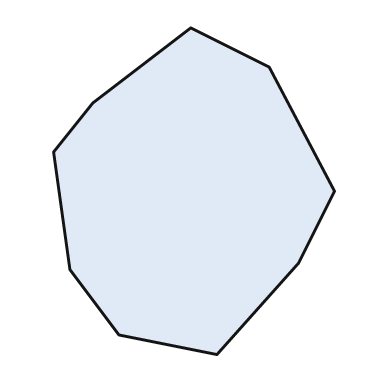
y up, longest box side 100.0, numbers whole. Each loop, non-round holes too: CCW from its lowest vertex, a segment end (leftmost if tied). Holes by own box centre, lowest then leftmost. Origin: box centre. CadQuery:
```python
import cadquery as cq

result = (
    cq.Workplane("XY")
    .moveTo(7.0, -50.0)
    .lineTo(32.0, -22.0)
    .lineTo(43.0, 0.0)
    .lineTo(23.0, 38.0)
    .lineTo(-1.0, 50.0)
    .lineTo(-31.0, 27.0)
    .lineTo(-43.0, 12.0)
    .lineTo(-38.0, -24.0)
    .lineTo(-23.0, -44.0)
    .close()
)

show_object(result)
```